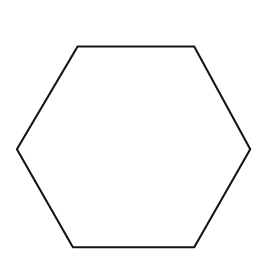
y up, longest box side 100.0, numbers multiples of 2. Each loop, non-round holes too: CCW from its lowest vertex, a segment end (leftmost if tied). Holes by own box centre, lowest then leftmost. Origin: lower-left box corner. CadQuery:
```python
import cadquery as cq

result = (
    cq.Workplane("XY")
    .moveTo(24.0, 0.0)
    .lineTo(76.0, 0.0)
    .lineTo(100.0, 42.0)
    .lineTo(76.0, 86.0)
    .lineTo(26.0, 86.0)
    .lineTo(0.0, 42.0)
    .close()
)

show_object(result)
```